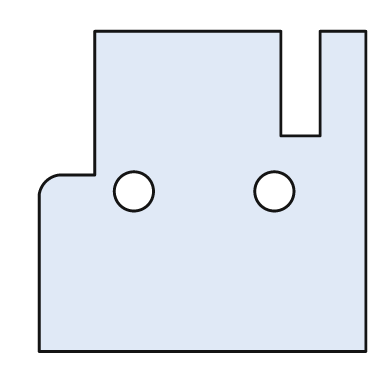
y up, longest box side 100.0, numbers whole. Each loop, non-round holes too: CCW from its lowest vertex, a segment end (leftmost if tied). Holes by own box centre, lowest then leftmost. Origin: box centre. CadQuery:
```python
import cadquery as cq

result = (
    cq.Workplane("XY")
    .moveTo(-50.0, -49.0)
    .lineTo(50.0, -49.0)
    .lineTo(50.0, 49.0)
    .lineTo(36.0, 49.0)
    .lineTo(36.0, 17.0)
    .lineTo(24.0, 17.0)
    .lineTo(24.0, 49.0)
    .lineTo(-33.0, 49.0)
    .lineTo(-33.0, 5.0)
    .lineTo(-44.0, 5.0)
    .threePointArc((-48.0, 3.0), (-50.0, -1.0))
    .close()
    .moveTo(-21.0, 0.0)
    .circle(6.0)
    .moveTo(22.0, 0.0)
    .circle(6.0)
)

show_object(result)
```